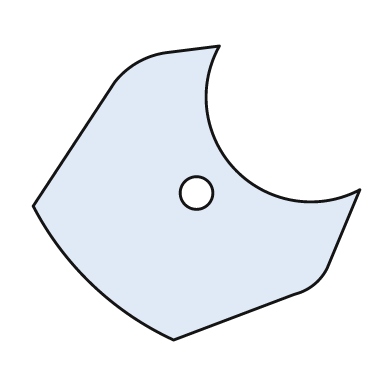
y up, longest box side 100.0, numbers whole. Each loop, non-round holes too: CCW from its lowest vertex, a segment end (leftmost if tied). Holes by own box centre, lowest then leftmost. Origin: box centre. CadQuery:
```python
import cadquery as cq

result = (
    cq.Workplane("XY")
    .moveTo(-7.0, -45.0)
    .lineTo(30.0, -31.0)
    .threePointArc((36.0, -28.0), (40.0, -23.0))
    .lineTo(50.0, 1.0)
    .threePointArc((12.0, 7.0), (7.0, 45.0))
    .lineTo(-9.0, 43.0)
    .threePointArc((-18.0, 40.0), (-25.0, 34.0))
    .lineTo(-50.0, -4.0)
    .threePointArc((-32.0, -28.0), (-7.0, -45.0))
    .close()
    .moveTo(0.0, 0.0)
    .circle(5.0)
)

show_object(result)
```